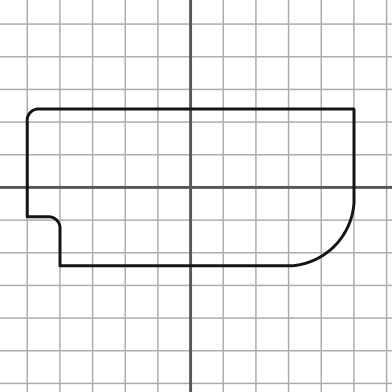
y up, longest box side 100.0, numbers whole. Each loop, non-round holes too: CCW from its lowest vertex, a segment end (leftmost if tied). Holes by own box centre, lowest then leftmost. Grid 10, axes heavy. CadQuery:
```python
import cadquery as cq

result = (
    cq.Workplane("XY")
    .moveTo(-40.0, -24.0)
    .lineTo(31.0, -24.0)
    .threePointArc((44.0, -18.0), (50.0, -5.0))
    .lineTo(50.0, 24.0)
    .lineTo(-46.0, 24.0)
    .threePointArc((-49.0, 23.0), (-50.0, 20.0))
    .lineTo(-50.0, -9.0)
    .lineTo(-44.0, -9.0)
    .threePointArc((-41.0, -10.0), (-40.0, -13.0))
    .close()
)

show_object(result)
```